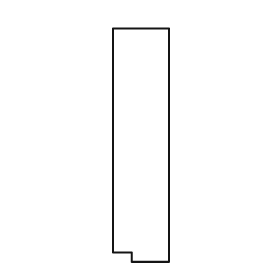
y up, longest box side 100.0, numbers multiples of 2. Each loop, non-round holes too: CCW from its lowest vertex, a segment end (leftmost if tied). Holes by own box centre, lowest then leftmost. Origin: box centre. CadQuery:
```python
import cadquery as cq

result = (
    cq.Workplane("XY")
    .moveTo(-4.0, -50.0)
    .lineTo(12.0, -50.0)
    .lineTo(12.0, 50.0)
    .lineTo(-12.0, 50.0)
    .lineTo(-12.0, -46.0)
    .lineTo(-4.0, -46.0)
    .close()
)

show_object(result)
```